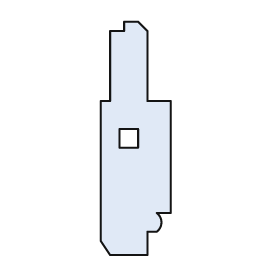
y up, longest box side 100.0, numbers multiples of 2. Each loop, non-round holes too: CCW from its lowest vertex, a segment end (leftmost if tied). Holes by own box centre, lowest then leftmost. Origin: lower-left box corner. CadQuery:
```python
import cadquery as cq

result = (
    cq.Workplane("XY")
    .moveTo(4.0, 0.0)
    .lineTo(20.0, 0.0)
    .lineTo(20.0, 10.0)
    .lineTo(24.0, 10.0)
    .threePointArc((26.0, 14.0), (24.0, 18.0))
    .lineTo(30.0, 18.0)
    .lineTo(30.0, 66.0)
    .lineTo(20.0, 66.0)
    .lineTo(20.0, 96.0)
    .lineTo(16.0, 100.0)
    .lineTo(10.0, 100.0)
    .lineTo(10.0, 96.0)
    .lineTo(4.0, 96.0)
    .lineTo(4.0, 66.0)
    .lineTo(0.0, 66.0)
    .lineTo(0.0, 6.0)
    .close()
    .moveTo(8.0, 46.0)
    .lineTo(16.0, 46.0)
    .lineTo(16.0, 54.0)
    .lineTo(8.0, 54.0)
    .close()
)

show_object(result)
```